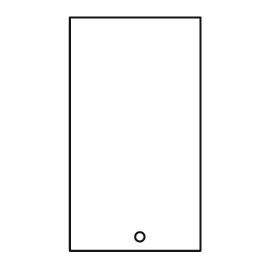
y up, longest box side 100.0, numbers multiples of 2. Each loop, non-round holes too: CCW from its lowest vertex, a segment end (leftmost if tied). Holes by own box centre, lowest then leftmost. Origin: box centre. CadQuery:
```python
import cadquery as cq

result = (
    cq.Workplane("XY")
    .moveTo(-28.0, -50.0)
    .lineTo(28.0, -50.0)
    .lineTo(28.0, 50.0)
    .lineTo(-28.0, 50.0)
    .close()
    .moveTo(2.0, -44.0)
    .circle(2.0)
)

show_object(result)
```